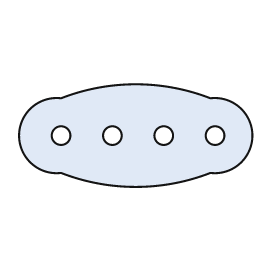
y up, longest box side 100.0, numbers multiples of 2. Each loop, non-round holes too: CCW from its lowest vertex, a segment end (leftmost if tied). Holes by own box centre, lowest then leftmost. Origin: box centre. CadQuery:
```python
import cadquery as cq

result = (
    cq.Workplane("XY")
    .moveTo(-32.0, -16.0)
    .threePointArc((0.0, -22.0), (32.0, -16.0))
    .threePointArc((50.0, 0.0), (32.0, 16.0))
    .threePointArc((0.0, 22.0), (-32.0, 16.0))
    .threePointArc((-50.0, 0.0), (-32.0, -16.0))
    .close()
    .moveTo(-32.0, 0.0)
    .circle(4.0)
    .moveTo(-10.0, 0.0)
    .circle(4.0)
    .moveTo(12.0, 0.0)
    .circle(4.0)
    .moveTo(34.0, 0.0)
    .circle(4.0)
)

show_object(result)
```